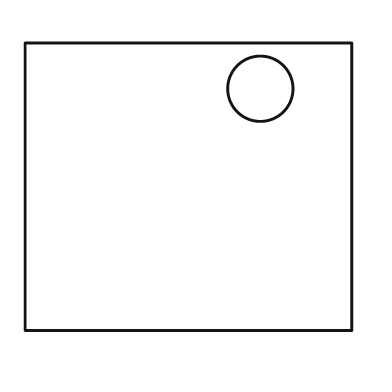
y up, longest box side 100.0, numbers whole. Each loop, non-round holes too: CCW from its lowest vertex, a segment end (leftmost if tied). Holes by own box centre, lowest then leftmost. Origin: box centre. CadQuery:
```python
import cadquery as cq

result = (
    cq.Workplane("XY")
    .moveTo(-50.0, -44.0)
    .lineTo(50.0, -44.0)
    .lineTo(50.0, 44.0)
    .lineTo(-50.0, 44.0)
    .close()
    .moveTo(22.0, 30.0)
    .circle(10.0)
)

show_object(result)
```